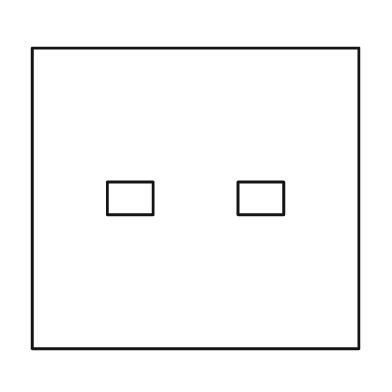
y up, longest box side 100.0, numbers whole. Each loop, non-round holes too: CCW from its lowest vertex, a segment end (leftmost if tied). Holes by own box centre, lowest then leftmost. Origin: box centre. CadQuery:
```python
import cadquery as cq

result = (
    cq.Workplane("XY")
    .moveTo(-50.0, -46.0)
    .lineTo(50.0, -46.0)
    .lineTo(50.0, 46.0)
    .lineTo(-50.0, 46.0)
    .close()
    .moveTo(-27.0, -5.0)
    .lineTo(-13.0, -5.0)
    .lineTo(-13.0, 5.0)
    .lineTo(-27.0, 5.0)
    .close()
    .moveTo(13.0, -5.0)
    .lineTo(27.0, -5.0)
    .lineTo(27.0, 5.0)
    .lineTo(13.0, 5.0)
    .close()
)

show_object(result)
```